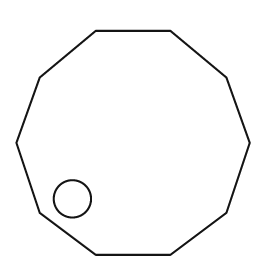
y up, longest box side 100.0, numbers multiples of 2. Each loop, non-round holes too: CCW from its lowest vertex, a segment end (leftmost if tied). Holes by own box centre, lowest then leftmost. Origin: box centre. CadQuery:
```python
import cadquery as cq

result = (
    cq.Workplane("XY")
    .moveTo(-16.0, -48.0)
    .lineTo(16.0, -48.0)
    .lineTo(40.0, -30.0)
    .lineTo(50.0, 0.0)
    .lineTo(40.0, 28.0)
    .lineTo(16.0, 48.0)
    .lineTo(-16.0, 48.0)
    .lineTo(-40.0, 28.0)
    .lineTo(-50.0, 0.0)
    .lineTo(-40.0, -30.0)
    .close()
    .moveTo(-26.0, -24.0)
    .circle(8.0)
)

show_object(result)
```